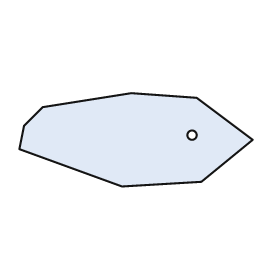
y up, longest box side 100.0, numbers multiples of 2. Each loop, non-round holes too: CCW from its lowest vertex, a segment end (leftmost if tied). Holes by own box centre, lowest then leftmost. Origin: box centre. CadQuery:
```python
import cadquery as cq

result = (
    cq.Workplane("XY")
    .moveTo(-6.0, -20.0)
    .lineTo(28.0, -18.0)
    .lineTo(50.0, 0.0)
    .lineTo(26.0, 18.0)
    .lineTo(-2.0, 20.0)
    .lineTo(-40.0, 14.0)
    .lineTo(-48.0, 6.0)
    .lineTo(-50.0, -4.0)
    .close()
    .moveTo(24.0, 2.0)
    .circle(2.0)
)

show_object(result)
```